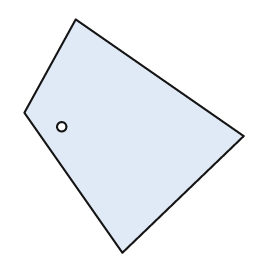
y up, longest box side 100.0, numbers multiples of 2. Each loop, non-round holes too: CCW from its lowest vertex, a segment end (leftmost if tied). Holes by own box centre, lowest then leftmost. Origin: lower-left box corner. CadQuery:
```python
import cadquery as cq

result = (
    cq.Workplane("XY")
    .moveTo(42.0, 0.0)
    .lineTo(94.0, 50.0)
    .lineTo(22.0, 100.0)
    .lineTo(0.0, 60.0)
    .close()
    .moveTo(16.0, 54.0)
    .circle(2.0)
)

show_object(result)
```